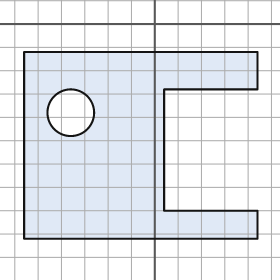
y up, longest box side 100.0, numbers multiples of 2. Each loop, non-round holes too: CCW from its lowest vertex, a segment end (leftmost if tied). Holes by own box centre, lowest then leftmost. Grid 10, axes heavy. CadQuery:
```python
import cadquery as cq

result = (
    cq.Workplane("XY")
    .moveTo(-56.0, -92.0)
    .lineTo(44.0, -92.0)
    .lineTo(44.0, -80.0)
    .lineTo(4.0, -80.0)
    .lineTo(4.0, -28.0)
    .lineTo(44.0, -28.0)
    .lineTo(44.0, -12.0)
    .lineTo(-56.0, -12.0)
    .close()
    .moveTo(-36.0, -38.0)
    .circle(10.0)
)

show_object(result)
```